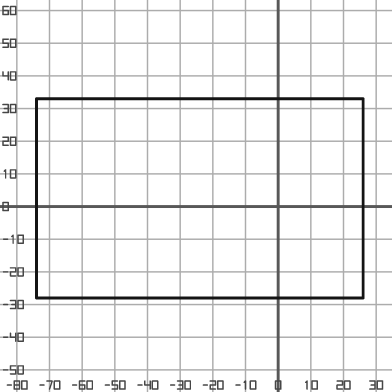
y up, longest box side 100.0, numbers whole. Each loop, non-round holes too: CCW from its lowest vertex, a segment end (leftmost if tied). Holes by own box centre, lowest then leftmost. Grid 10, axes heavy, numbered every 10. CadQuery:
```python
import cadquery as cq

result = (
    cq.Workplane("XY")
    .moveTo(-74.0, -28.0)
    .lineTo(26.0, -28.0)
    .lineTo(26.0, 33.0)
    .lineTo(-74.0, 33.0)
    .close()
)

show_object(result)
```